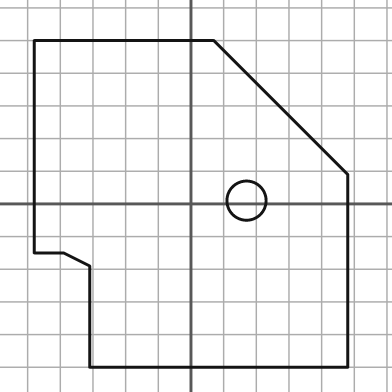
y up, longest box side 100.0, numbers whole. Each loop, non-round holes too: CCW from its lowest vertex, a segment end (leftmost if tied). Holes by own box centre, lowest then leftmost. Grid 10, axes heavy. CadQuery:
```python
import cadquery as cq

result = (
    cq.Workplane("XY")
    .moveTo(-31.0, -50.0)
    .lineTo(48.0, -50.0)
    .lineTo(48.0, 9.0)
    .lineTo(7.0, 50.0)
    .lineTo(-48.0, 50.0)
    .lineTo(-48.0, -15.0)
    .lineTo(-39.0, -15.0)
    .lineTo(-31.0, -19.0)
    .close()
    .moveTo(17.0, 1.0)
    .circle(6.0)
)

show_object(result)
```